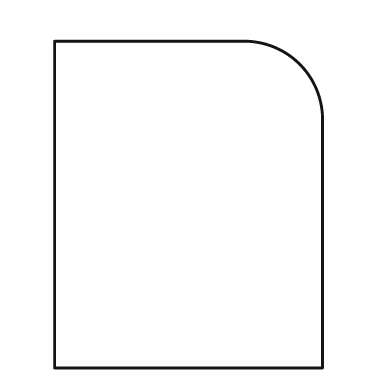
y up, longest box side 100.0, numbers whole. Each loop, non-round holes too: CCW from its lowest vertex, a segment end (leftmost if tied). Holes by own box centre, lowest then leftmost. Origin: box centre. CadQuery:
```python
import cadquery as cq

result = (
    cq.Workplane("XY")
    .moveTo(-41.0, -50.0)
    .lineTo(41.0, -50.0)
    .lineTo(41.0, 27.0)
    .threePointArc((34.0, 43.0), (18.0, 50.0))
    .lineTo(-41.0, 50.0)
    .close()
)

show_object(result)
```